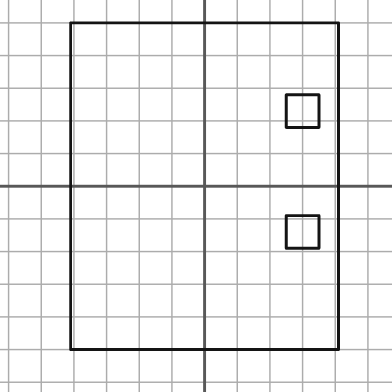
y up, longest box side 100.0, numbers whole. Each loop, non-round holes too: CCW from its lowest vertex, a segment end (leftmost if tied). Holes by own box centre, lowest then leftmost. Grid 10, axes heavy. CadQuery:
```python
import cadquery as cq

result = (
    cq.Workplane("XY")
    .moveTo(-41.0, -50.0)
    .lineTo(41.0, -50.0)
    .lineTo(41.0, 50.0)
    .lineTo(-41.0, 50.0)
    .close()
    .moveTo(25.0, -19.0)
    .lineTo(35.0, -19.0)
    .lineTo(35.0, -9.0)
    .lineTo(25.0, -9.0)
    .close()
    .moveTo(25.0, 18.0)
    .lineTo(35.0, 18.0)
    .lineTo(35.0, 28.0)
    .lineTo(25.0, 28.0)
    .close()
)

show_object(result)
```